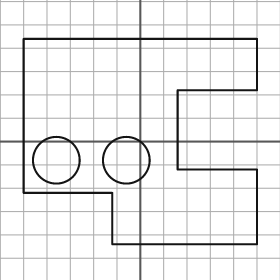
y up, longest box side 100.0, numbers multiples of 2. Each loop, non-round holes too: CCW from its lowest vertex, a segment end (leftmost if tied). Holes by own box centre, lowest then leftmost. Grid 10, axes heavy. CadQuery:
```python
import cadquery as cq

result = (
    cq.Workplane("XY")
    .moveTo(-12.0, -44.0)
    .lineTo(50.0, -44.0)
    .lineTo(50.0, -12.0)
    .lineTo(16.0, -12.0)
    .lineTo(16.0, 22.0)
    .lineTo(50.0, 22.0)
    .lineTo(50.0, 44.0)
    .lineTo(-50.0, 44.0)
    .lineTo(-50.0, -22.0)
    .lineTo(-12.0, -22.0)
    .close()
    .moveTo(-36.0, -8.0)
    .circle(10.0)
    .moveTo(-6.0, -8.0)
    .circle(10.0)
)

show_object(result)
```